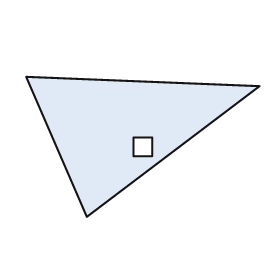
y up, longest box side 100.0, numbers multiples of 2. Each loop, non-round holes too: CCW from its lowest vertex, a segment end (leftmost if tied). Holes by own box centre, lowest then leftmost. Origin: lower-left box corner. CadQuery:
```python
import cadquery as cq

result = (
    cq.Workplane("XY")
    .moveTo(26.0, 0.0)
    .lineTo(100.0, 56.0)
    .lineTo(0.0, 60.0)
    .close()
    .moveTo(46.0, 26.0)
    .lineTo(54.0, 26.0)
    .lineTo(54.0, 34.0)
    .lineTo(46.0, 34.0)
    .close()
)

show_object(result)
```